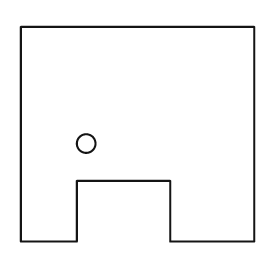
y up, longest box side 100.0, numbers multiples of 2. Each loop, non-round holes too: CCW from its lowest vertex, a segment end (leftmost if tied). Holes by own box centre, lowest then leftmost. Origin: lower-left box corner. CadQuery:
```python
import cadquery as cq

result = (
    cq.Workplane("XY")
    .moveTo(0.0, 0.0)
    .lineTo(24.0, 0.0)
    .lineTo(24.0, 26.0)
    .lineTo(64.0, 26.0)
    .lineTo(64.0, 0.0)
    .lineTo(100.0, 0.0)
    .lineTo(100.0, 92.0)
    .lineTo(0.0, 92.0)
    .close()
    .moveTo(28.0, 42.0)
    .circle(4.0)
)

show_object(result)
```